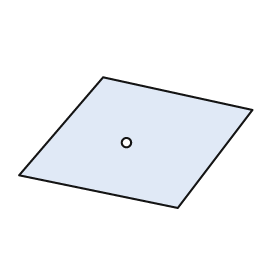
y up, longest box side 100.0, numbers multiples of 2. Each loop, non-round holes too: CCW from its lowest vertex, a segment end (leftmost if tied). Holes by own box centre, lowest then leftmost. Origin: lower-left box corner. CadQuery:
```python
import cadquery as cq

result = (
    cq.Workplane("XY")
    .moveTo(68.0, 0.0)
    .lineTo(100.0, 42.0)
    .lineTo(36.0, 56.0)
    .lineTo(0.0, 14.0)
    .close()
    .moveTo(46.0, 28.0)
    .circle(2.0)
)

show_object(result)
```